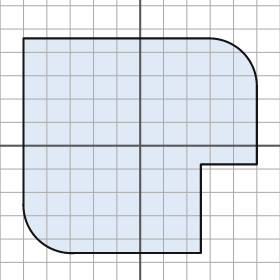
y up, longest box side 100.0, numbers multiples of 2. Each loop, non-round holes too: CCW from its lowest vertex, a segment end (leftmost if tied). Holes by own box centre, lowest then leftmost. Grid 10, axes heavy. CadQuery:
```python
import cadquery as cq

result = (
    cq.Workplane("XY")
    .moveTo(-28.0, -46.0)
    .lineTo(26.0, -46.0)
    .lineTo(26.0, -8.0)
    .lineTo(50.0, -8.0)
    .lineTo(50.0, 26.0)
    .threePointArc((44.0, 40.0), (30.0, 46.0))
    .lineTo(-50.0, 46.0)
    .lineTo(-50.0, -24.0)
    .threePointArc((-44.0, -40.0), (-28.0, -46.0))
    .close()
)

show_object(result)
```